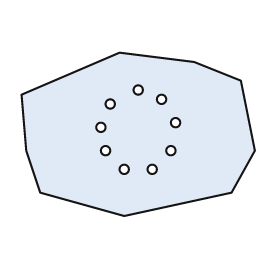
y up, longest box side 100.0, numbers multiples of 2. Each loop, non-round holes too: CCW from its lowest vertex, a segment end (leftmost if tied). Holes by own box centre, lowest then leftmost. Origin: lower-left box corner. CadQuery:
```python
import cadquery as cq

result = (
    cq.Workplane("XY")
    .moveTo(44.0, 0.0)
    .lineTo(90.0, 10.0)
    .lineTo(100.0, 28.0)
    .lineTo(94.0, 58.0)
    .lineTo(74.0, 66.0)
    .lineTo(42.0, 70.0)
    .lineTo(0.0, 52.0)
    .lineTo(2.0, 28.0)
    .lineTo(8.0, 10.0)
    .close()
    .moveTo(44.0, 20.0)
    .circle(2.0)
    .moveTo(56.0, 20.0)
    .circle(2.0)
    .moveTo(36.0, 28.0)
    .circle(2.0)
    .moveTo(64.0, 28.0)
    .circle(2.0)
    .moveTo(34.0, 38.0)
    .circle(2.0)
    .moveTo(66.0, 40.0)
    .circle(2.0)
    .moveTo(38.0, 48.0)
    .circle(2.0)
    .moveTo(60.0, 50.0)
    .circle(2.0)
    .moveTo(50.0, 54.0)
    .circle(2.0)
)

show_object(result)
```